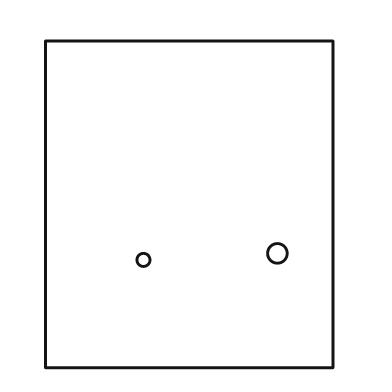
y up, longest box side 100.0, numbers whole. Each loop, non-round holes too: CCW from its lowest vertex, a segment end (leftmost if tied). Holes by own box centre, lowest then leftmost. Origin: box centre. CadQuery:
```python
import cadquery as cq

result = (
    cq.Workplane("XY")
    .moveTo(-44.0, -50.0)
    .lineTo(44.0, -50.0)
    .lineTo(44.0, 50.0)
    .lineTo(-44.0, 50.0)
    .close()
    .moveTo(-14.0, -17.0)
    .circle(2.0)
    .moveTo(27.0, -15.0)
    .circle(3.0)
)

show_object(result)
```